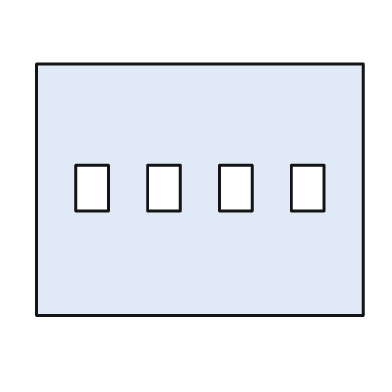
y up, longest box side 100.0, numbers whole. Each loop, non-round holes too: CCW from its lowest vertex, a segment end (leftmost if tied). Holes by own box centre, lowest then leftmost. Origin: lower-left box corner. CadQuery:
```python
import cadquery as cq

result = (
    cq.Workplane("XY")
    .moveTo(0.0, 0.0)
    .lineTo(100.0, 0.0)
    .lineTo(100.0, 77.0)
    .lineTo(0.0, 77.0)
    .close()
    .moveTo(12.0, 32.0)
    .lineTo(22.0, 32.0)
    .lineTo(22.0, 46.0)
    .lineTo(12.0, 46.0)
    .close()
    .moveTo(34.0, 32.0)
    .lineTo(44.0, 32.0)
    .lineTo(44.0, 46.0)
    .lineTo(34.0, 46.0)
    .close()
    .moveTo(56.0, 32.0)
    .lineTo(66.0, 32.0)
    .lineTo(66.0, 46.0)
    .lineTo(56.0, 46.0)
    .close()
    .moveTo(78.0, 32.0)
    .lineTo(88.0, 32.0)
    .lineTo(88.0, 46.0)
    .lineTo(78.0, 46.0)
    .close()
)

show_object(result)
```